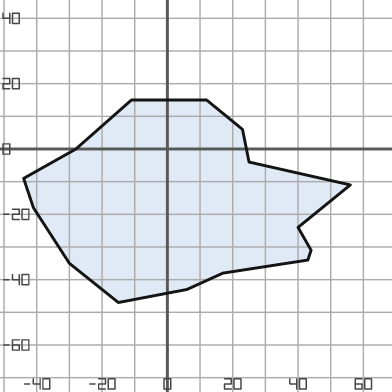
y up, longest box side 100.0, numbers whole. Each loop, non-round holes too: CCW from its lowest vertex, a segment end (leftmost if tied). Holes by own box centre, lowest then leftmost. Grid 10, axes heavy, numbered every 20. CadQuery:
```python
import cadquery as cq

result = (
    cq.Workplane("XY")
    .moveTo(-15.0, -47.0)
    .lineTo(6.0, -43.0)
    .lineTo(17.0, -38.0)
    .lineTo(43.0, -34.0)
    .lineTo(44.0, -31.0)
    .lineTo(40.0, -24.0)
    .lineTo(56.0, -11.0)
    .lineTo(25.0, -4.0)
    .lineTo(23.0, 6.0)
    .lineTo(12.0, 15.0)
    .lineTo(-11.0, 15.0)
    .lineTo(-28.0, 0.0)
    .lineTo(-44.0, -9.0)
    .lineTo(-41.0, -18.0)
    .lineTo(-30.0, -35.0)
    .close()
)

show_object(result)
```